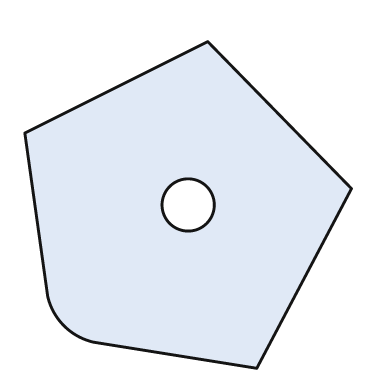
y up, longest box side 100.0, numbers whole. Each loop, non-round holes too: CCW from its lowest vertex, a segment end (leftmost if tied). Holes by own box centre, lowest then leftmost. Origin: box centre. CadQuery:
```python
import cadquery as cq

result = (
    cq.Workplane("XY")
    .moveTo(21.0, -50.0)
    .lineTo(50.0, 5.0)
    .lineTo(6.0, 50.0)
    .lineTo(-50.0, 22.0)
    .lineTo(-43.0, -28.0)
    .threePointArc((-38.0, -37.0), (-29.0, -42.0))
    .close()
    .moveTo(0.0, 0.0)
    .circle(8.0)
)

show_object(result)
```